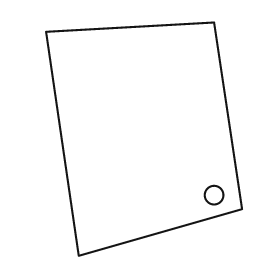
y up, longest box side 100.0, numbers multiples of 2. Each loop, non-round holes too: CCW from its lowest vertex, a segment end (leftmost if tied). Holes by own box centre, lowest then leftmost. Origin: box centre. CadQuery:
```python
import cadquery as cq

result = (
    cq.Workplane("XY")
    .moveTo(-28.0, -50.0)
    .lineTo(42.0, -30.0)
    .lineTo(30.0, 50.0)
    .lineTo(-42.0, 46.0)
    .close()
    .moveTo(30.0, -24.0)
    .circle(4.0)
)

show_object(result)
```